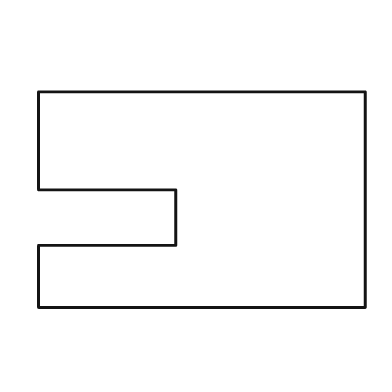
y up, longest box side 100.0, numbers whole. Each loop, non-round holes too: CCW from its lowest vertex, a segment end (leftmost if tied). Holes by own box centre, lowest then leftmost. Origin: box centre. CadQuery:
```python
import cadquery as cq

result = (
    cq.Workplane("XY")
    .moveTo(-50.0, -33.0)
    .lineTo(50.0, -33.0)
    .lineTo(50.0, 33.0)
    .lineTo(-50.0, 33.0)
    .lineTo(-50.0, 3.0)
    .lineTo(-8.0, 3.0)
    .lineTo(-8.0, -14.0)
    .lineTo(-50.0, -14.0)
    .close()
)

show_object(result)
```